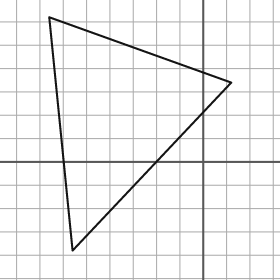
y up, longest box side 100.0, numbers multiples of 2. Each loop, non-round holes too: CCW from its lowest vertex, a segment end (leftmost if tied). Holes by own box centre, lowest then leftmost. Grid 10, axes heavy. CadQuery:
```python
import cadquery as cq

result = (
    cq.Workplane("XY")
    .moveTo(-56.0, -38.0)
    .lineTo(12.0, 34.0)
    .lineTo(-66.0, 62.0)
    .close()
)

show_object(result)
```